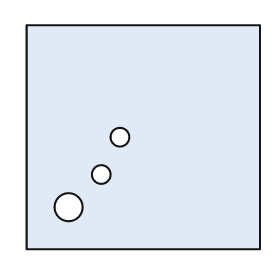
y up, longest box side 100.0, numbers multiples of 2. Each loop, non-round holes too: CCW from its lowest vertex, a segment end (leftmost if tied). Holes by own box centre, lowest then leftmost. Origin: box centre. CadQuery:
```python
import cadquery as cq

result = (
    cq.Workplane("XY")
    .moveTo(-50.0, -48.0)
    .lineTo(50.0, -48.0)
    .lineTo(50.0, 48.0)
    .lineTo(-50.0, 48.0)
    .close()
    .moveTo(-32.0, -30.0)
    .circle(6.0)
    .moveTo(-18.0, -16.0)
    .circle(4.0)
    .moveTo(-10.0, 0.0)
    .circle(4.0)
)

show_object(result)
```